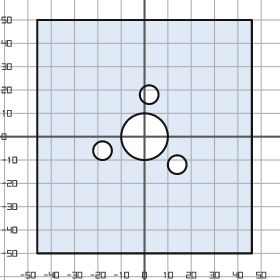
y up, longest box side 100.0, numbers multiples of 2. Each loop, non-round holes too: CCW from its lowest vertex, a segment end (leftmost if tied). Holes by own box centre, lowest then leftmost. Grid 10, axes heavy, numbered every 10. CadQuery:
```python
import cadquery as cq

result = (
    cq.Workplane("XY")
    .moveTo(-46.0, -50.0)
    .lineTo(46.0, -50.0)
    .lineTo(46.0, 50.0)
    .lineTo(-46.0, 50.0)
    .close()
    .moveTo(14.0, -12.0)
    .circle(4.0)
    .moveTo(-18.0, -6.0)
    .circle(4.0)
    .moveTo(0.0, 0.0)
    .circle(10.0)
    .moveTo(2.0, 18.0)
    .circle(4.0)
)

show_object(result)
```